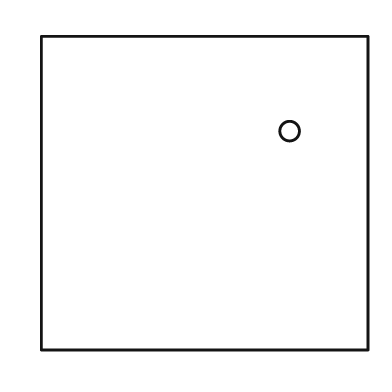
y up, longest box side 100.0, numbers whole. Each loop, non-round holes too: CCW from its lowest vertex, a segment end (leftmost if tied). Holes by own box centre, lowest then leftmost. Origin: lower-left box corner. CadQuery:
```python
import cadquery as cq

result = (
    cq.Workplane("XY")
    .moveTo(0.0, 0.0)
    .lineTo(100.0, 0.0)
    .lineTo(100.0, 96.0)
    .lineTo(0.0, 96.0)
    .close()
    .moveTo(76.0, 67.0)
    .circle(3.0)
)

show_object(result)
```